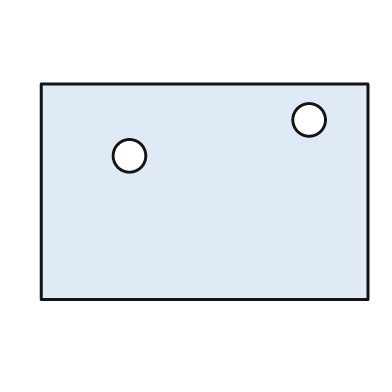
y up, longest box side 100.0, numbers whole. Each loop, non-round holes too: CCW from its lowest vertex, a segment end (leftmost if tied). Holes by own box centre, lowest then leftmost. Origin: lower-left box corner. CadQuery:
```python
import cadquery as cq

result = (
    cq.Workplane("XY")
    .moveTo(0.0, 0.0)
    .lineTo(100.0, 0.0)
    .lineTo(100.0, 66.0)
    .lineTo(0.0, 66.0)
    .close()
    .moveTo(27.0, 44.0)
    .circle(5.0)
    .moveTo(82.0, 55.0)
    .circle(5.0)
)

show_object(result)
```